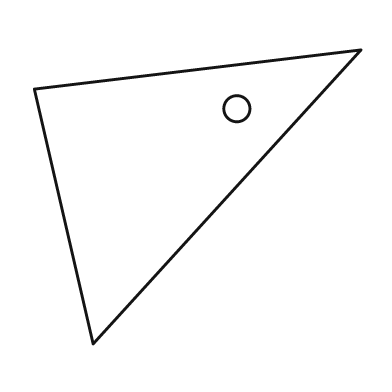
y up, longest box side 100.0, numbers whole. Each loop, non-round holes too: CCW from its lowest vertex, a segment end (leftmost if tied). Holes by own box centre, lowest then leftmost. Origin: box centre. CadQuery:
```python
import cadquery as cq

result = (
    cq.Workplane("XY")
    .moveTo(-32.0, -45.0)
    .lineTo(50.0, 45.0)
    .lineTo(-50.0, 33.0)
    .close()
    .moveTo(12.0, 27.0)
    .circle(4.0)
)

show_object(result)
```